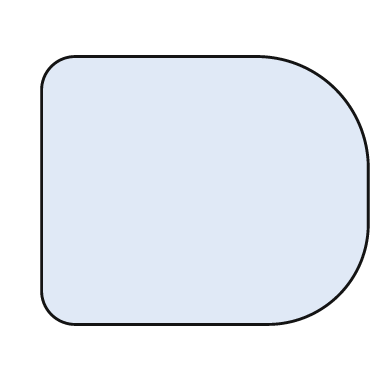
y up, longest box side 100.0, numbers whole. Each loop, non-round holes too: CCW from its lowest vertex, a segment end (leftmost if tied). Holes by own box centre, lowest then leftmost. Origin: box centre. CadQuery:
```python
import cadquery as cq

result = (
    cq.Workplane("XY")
    .moveTo(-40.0, -41.0)
    .lineTo(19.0, -41.0)
    .threePointArc((41.0, -32.0), (50.0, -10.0))
    .lineTo(50.0, 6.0)
    .threePointArc((40.0, 31.0), (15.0, 41.0))
    .lineTo(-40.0, 41.0)
    .threePointArc((-47.0, 38.0), (-50.0, 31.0))
    .lineTo(-50.0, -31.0)
    .threePointArc((-47.0, -38.0), (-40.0, -41.0))
    .close()
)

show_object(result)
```